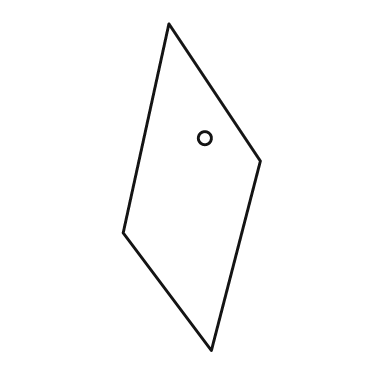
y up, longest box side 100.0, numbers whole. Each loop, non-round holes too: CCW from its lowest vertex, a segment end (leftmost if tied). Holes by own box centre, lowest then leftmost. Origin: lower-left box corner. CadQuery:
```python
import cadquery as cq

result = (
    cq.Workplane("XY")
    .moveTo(27.0, 0.0)
    .lineTo(42.0, 58.0)
    .lineTo(14.0, 100.0)
    .lineTo(0.0, 36.0)
    .close()
    .moveTo(25.0, 65.0)
    .circle(2.0)
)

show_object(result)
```